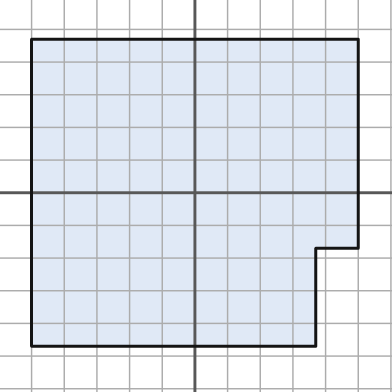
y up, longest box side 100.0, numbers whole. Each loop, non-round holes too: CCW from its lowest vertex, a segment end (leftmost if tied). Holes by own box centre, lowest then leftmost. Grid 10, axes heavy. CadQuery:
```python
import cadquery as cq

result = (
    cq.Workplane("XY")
    .moveTo(-50.0, -47.0)
    .lineTo(37.0, -47.0)
    .lineTo(37.0, -17.0)
    .lineTo(50.0, -17.0)
    .lineTo(50.0, 47.0)
    .lineTo(-50.0, 47.0)
    .close()
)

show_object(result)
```